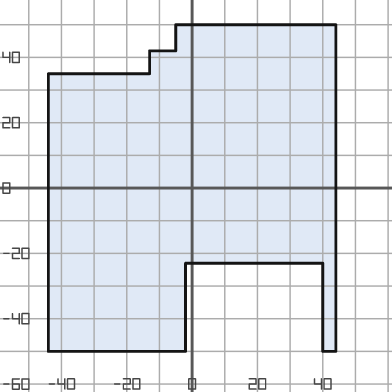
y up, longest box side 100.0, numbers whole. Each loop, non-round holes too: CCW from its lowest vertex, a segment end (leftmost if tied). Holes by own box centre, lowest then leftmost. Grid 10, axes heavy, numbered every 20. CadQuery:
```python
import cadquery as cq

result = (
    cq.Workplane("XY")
    .moveTo(-44.0, -50.0)
    .lineTo(-2.0, -50.0)
    .lineTo(-2.0, -23.0)
    .lineTo(40.0, -23.0)
    .lineTo(40.0, -50.0)
    .lineTo(44.0, -50.0)
    .lineTo(44.0, 50.0)
    .lineTo(-5.0, 50.0)
    .lineTo(-5.0, 42.0)
    .lineTo(-13.0, 42.0)
    .lineTo(-13.0, 35.0)
    .lineTo(-44.0, 35.0)
    .close()
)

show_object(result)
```